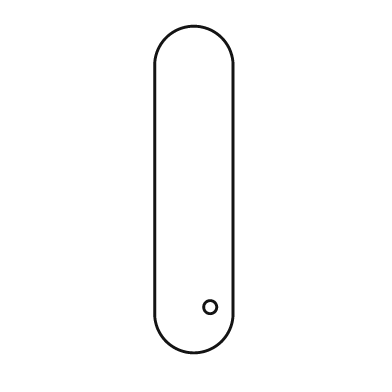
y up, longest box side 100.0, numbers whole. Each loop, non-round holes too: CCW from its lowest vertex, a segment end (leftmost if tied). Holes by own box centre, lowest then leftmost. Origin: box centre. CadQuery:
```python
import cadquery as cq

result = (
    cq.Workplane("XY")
    .moveTo(-12.0, -38.0)
    .threePointArc((0.0, -50.0), (12.0, -38.0))
    .lineTo(12.0, 38.0)
    .threePointArc((0.0, 50.0), (-12.0, 38.0))
    .close()
    .moveTo(5.0, -36.0)
    .circle(2.0)
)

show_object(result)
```